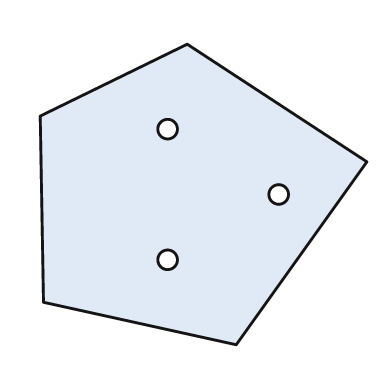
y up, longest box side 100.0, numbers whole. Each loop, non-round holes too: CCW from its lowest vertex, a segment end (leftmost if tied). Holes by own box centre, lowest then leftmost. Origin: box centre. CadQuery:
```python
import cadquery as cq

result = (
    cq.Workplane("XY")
    .moveTo(10.0, -46.0)
    .lineTo(50.0, 10.0)
    .lineTo(-5.0, 46.0)
    .lineTo(-50.0, 24.0)
    .lineTo(-49.0, -33.0)
    .close()
    .moveTo(-11.0, -20.0)
    .circle(3.0)
    .moveTo(23.0, 0.0)
    .circle(3.0)
    .moveTo(-11.0, 20.0)
    .circle(3.0)
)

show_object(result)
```